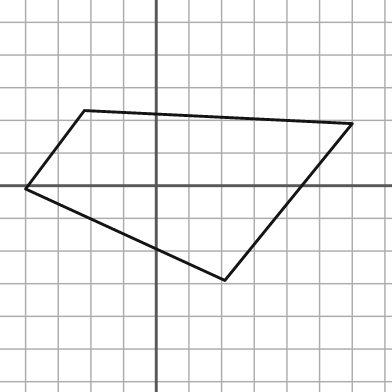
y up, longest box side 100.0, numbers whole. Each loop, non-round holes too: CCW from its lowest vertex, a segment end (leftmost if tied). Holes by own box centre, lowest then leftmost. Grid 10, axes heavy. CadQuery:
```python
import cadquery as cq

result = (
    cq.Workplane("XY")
    .moveTo(21.0, -29.0)
    .lineTo(60.0, 19.0)
    .lineTo(-22.0, 23.0)
    .lineTo(-40.0, -1.0)
    .close()
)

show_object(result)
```